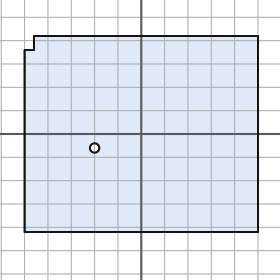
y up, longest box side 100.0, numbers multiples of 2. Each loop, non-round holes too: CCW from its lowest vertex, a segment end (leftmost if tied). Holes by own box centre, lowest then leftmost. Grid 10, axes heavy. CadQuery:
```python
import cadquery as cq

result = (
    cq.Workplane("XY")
    .moveTo(-50.0, -42.0)
    .lineTo(50.0, -42.0)
    .lineTo(50.0, 42.0)
    .lineTo(-46.0, 42.0)
    .lineTo(-46.0, 36.0)
    .lineTo(-50.0, 36.0)
    .close()
    .moveTo(-20.0, -6.0)
    .circle(2.0)
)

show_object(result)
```